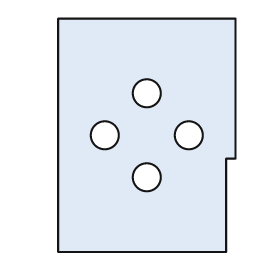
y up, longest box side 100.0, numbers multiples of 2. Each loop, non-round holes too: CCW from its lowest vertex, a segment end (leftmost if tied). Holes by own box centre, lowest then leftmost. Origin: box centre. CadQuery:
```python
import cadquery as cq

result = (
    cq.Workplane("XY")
    .moveTo(-38.0, -50.0)
    .lineTo(34.0, -50.0)
    .lineTo(34.0, -10.0)
    .lineTo(38.0, -10.0)
    .lineTo(38.0, 50.0)
    .lineTo(-38.0, 50.0)
    .close()
    .moveTo(0.0, -18.0)
    .circle(6.0)
    .moveTo(-18.0, 0.0)
    .circle(6.0)
    .moveTo(18.0, 0.0)
    .circle(6.0)
    .moveTo(0.0, 18.0)
    .circle(6.0)
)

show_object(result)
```